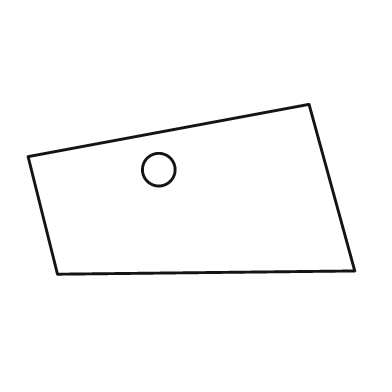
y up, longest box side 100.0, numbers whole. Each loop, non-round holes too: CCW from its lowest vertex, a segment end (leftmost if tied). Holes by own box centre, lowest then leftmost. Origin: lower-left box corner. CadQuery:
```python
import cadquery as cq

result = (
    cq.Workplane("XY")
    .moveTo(9.0, 0.0)
    .lineTo(100.0, 1.0)
    .lineTo(86.0, 52.0)
    .lineTo(0.0, 36.0)
    .close()
    .moveTo(40.0, 32.0)
    .circle(5.0)
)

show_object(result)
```